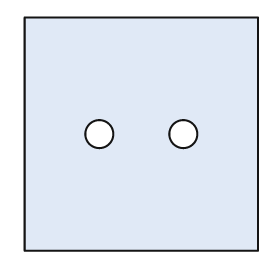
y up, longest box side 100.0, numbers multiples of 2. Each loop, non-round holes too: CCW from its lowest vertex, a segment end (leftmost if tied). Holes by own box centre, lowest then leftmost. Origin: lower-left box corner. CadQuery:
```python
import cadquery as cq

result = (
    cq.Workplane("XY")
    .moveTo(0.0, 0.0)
    .lineTo(100.0, 0.0)
    .lineTo(100.0, 100.0)
    .lineTo(0.0, 100.0)
    .close()
    .moveTo(32.0, 50.0)
    .circle(6.0)
    .moveTo(68.0, 50.0)
    .circle(6.0)
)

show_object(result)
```